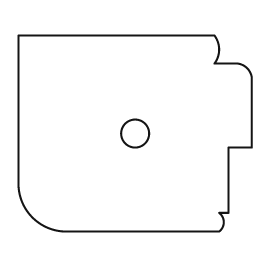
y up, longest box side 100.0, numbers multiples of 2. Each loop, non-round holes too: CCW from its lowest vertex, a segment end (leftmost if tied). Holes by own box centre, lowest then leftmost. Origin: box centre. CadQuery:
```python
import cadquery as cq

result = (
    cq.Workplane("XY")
    .moveTo(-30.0, -42.0)
    .lineTo(36.0, -42.0)
    .threePointArc((38.0, -38.0), (36.0, -34.0))
    .lineTo(40.0, -34.0)
    .lineTo(40.0, -6.0)
    .lineTo(50.0, -6.0)
    .lineTo(50.0, 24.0)
    .threePointArc((48.0, 28.0), (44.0, 30.0))
    .lineTo(34.0, 30.0)
    .threePointArc((36.0, 36.0), (34.0, 42.0))
    .lineTo(-50.0, 42.0)
    .lineTo(-50.0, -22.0)
    .threePointArc((-44.0, -36.0), (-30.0, -42.0))
    .close()
    .moveTo(0.0, 0.0)
    .circle(6.0)
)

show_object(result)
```